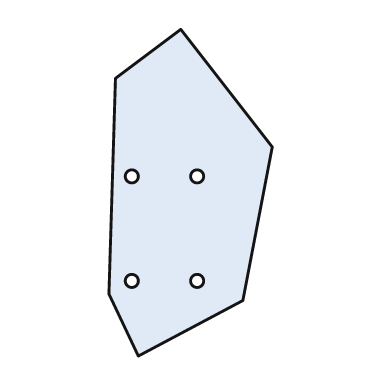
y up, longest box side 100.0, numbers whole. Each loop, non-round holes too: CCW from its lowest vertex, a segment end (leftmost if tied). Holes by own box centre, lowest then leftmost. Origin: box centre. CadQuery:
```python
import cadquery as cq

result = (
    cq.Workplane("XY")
    .moveTo(-16.0, -50.0)
    .lineTo(16.0, -33.0)
    .lineTo(25.0, 14.0)
    .lineTo(-3.0, 50.0)
    .lineTo(-23.0, 35.0)
    .lineTo(-25.0, -31.0)
    .close()
    .moveTo(-18.0, -27.0)
    .circle(2.0)
    .moveTo(2.0, -27.0)
    .circle(2.0)
    .moveTo(-18.0, 5.0)
    .circle(2.0)
    .moveTo(2.0, 5.0)
    .circle(2.0)
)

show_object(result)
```